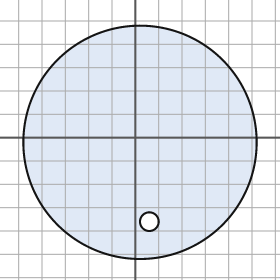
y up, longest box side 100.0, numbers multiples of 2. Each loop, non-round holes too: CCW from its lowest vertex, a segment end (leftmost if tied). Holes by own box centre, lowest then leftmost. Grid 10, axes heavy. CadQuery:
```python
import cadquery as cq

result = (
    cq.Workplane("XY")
    .moveTo(2.0, -2.0)
    .circle(50.0)
    .moveTo(6.0, -36.0)
    .circle(4.0)
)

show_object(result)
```